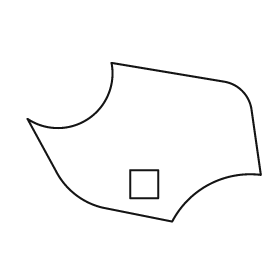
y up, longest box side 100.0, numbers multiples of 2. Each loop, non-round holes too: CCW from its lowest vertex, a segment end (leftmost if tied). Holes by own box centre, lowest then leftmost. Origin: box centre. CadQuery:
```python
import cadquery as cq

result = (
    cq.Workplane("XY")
    .moveTo(12.0, -34.0)
    .threePointArc((28.0, -18.0), (50.0, -14.0))
    .lineTo(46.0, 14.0)
    .threePointArc((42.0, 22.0), (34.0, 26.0))
    .lineTo(-14.0, 34.0)
    .threePointArc((-24.0, 10.0), (-50.0, 10.0))
    .lineTo(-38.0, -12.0)
    .threePointArc((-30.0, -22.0), (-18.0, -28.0))
    .close()
    .moveTo(-6.0, -24.0)
    .lineTo(6.0, -24.0)
    .lineTo(6.0, -12.0)
    .lineTo(-6.0, -12.0)
    .close()
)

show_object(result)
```